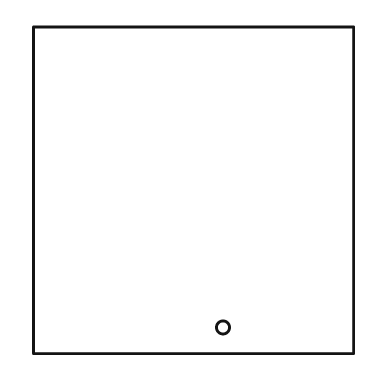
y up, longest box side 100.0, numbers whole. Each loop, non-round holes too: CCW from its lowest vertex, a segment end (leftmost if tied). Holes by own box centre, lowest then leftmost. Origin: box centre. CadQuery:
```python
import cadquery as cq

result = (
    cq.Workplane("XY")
    .moveTo(-49.0, -50.0)
    .lineTo(49.0, -50.0)
    .lineTo(49.0, 50.0)
    .lineTo(-49.0, 50.0)
    .close()
    .moveTo(9.0, -42.0)
    .circle(2.0)
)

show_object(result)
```